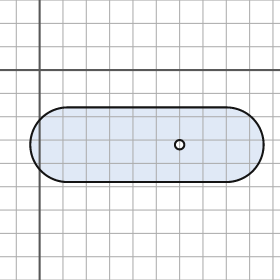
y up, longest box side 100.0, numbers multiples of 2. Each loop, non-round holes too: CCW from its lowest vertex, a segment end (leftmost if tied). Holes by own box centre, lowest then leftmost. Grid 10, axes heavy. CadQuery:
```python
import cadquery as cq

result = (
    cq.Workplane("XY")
    .moveTo(12.0, -48.0)
    .lineTo(80.0, -48.0)
    .threePointArc((96.0, -32.0), (80.0, -16.0))
    .lineTo(12.0, -16.0)
    .threePointArc((-4.0, -32.0), (12.0, -48.0))
    .close()
    .moveTo(60.0, -32.0)
    .circle(2.0)
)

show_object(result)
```